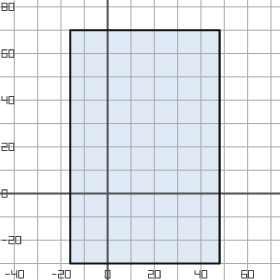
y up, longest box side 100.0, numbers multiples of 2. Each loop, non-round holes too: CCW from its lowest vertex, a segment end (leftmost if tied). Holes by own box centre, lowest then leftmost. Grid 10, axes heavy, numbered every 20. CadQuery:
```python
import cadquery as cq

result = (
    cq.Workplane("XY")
    .moveTo(-16.0, -30.0)
    .lineTo(48.0, -30.0)
    .lineTo(48.0, 70.0)
    .lineTo(-16.0, 70.0)
    .close()
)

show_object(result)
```